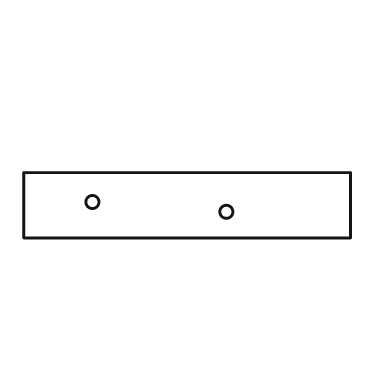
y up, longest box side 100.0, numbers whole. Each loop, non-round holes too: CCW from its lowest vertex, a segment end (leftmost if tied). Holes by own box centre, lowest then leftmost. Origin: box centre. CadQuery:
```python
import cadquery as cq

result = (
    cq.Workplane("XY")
    .moveTo(-50.0, -10.0)
    .lineTo(50.0, -10.0)
    .lineTo(50.0, 10.0)
    .lineTo(-50.0, 10.0)
    .close()
    .moveTo(12.0, -2.0)
    .circle(2.0)
    .moveTo(-29.0, 1.0)
    .circle(2.0)
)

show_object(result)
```